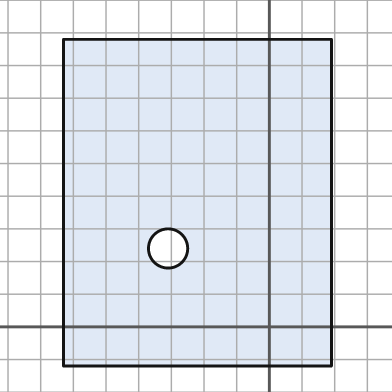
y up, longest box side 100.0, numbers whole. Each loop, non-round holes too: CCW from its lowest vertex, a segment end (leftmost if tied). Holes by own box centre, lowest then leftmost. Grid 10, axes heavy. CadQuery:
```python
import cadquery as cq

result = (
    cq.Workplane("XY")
    .moveTo(-63.0, -12.0)
    .lineTo(19.0, -12.0)
    .lineTo(19.0, 88.0)
    .lineTo(-63.0, 88.0)
    .close()
    .moveTo(-31.0, 24.0)
    .circle(6.0)
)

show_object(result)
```